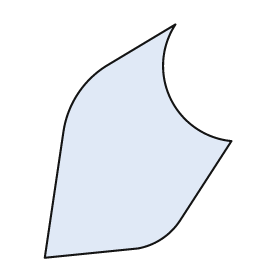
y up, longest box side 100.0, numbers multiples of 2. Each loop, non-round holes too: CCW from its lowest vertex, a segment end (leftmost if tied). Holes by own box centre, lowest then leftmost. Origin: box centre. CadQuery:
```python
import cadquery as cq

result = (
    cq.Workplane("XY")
    .moveTo(-40.0, -50.0)
    .lineTo(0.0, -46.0)
    .threePointArc((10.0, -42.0), (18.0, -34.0))
    .lineTo(40.0, 0.0)
    .threePointArc((14.0, 18.0), (16.0, 50.0))
    .lineTo(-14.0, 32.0)
    .threePointArc((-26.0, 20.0), (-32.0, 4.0))
    .close()
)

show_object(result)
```